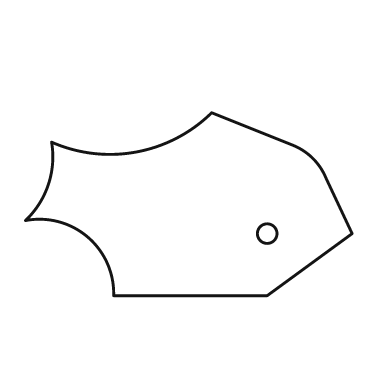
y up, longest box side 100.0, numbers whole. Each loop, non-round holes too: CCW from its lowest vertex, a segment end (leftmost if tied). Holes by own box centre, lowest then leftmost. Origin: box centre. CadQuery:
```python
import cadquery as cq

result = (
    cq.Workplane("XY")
    .moveTo(-23.0, -28.0)
    .lineTo(24.0, -28.0)
    .lineTo(50.0, -9.0)
    .lineTo(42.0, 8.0)
    .threePointArc((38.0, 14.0), (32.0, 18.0))
    .lineTo(7.0, 28.0)
    .threePointArc((-16.0, 16.0), (-42.0, 19.0))
    .threePointArc((-43.0, 6.0), (-50.0, -5.0))
    .threePointArc((-31.0, -10.0), (-23.0, -28.0))
    .close()
    .moveTo(24.0, -9.0)
    .circle(3.0)
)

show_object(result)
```